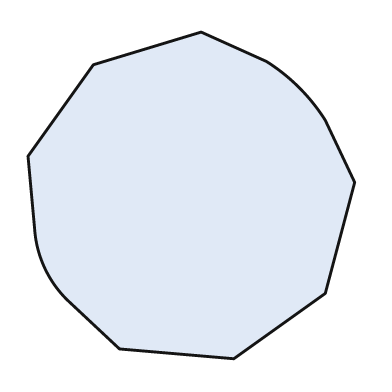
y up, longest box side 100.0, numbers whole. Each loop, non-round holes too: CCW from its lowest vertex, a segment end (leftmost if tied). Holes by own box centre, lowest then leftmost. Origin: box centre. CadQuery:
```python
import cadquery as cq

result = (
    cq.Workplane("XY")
    .moveTo(13.0, -50.0)
    .lineTo(41.0, -30.0)
    .lineTo(50.0, 4.0)
    .lineTo(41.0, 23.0)
    .threePointArc((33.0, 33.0), (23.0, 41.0))
    .lineTo(3.0, 50.0)
    .lineTo(-30.0, 40.0)
    .lineTo(-50.0, 12.0)
    .lineTo(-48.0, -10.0)
    .threePointArc((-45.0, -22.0), (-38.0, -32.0))
    .lineTo(-22.0, -47.0)
    .close()
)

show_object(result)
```